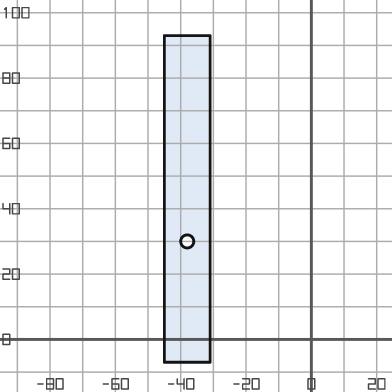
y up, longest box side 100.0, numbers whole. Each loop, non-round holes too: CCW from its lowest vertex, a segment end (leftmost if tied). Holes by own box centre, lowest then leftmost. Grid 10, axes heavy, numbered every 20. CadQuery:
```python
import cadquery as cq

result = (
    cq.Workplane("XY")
    .moveTo(-45.0, -7.0)
    .lineTo(-31.0, -7.0)
    .lineTo(-31.0, 93.0)
    .lineTo(-45.0, 93.0)
    .close()
    .moveTo(-38.0, 30.0)
    .circle(2.0)
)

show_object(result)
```